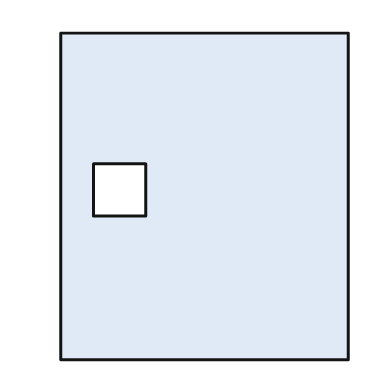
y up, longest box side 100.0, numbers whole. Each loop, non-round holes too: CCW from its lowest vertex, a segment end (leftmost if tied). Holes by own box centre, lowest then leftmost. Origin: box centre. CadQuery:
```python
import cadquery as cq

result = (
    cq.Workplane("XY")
    .moveTo(-44.0, -50.0)
    .lineTo(44.0, -50.0)
    .lineTo(44.0, 50.0)
    .lineTo(-44.0, 50.0)
    .close()
    .moveTo(-34.0, -6.0)
    .lineTo(-18.0, -6.0)
    .lineTo(-18.0, 10.0)
    .lineTo(-34.0, 10.0)
    .close()
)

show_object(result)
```